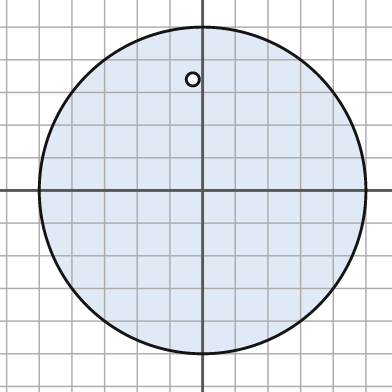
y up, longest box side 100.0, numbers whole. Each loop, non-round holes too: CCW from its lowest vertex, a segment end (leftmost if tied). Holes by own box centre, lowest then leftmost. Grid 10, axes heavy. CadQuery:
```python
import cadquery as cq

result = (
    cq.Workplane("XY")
    .moveTo(0.0, 0.0)
    .circle(50.0)
    .moveTo(-3.0, 34.0)
    .circle(2.0)
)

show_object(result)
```